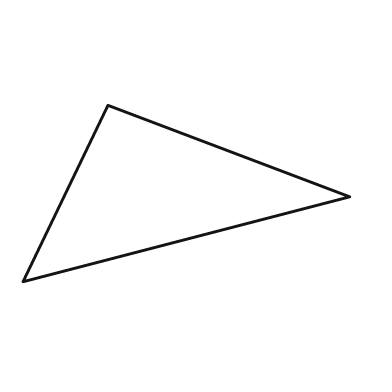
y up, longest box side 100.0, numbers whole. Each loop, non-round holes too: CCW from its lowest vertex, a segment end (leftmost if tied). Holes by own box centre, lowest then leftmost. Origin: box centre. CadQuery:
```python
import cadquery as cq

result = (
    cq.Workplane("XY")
    .moveTo(-50.0, -27.0)
    .lineTo(50.0, -1.0)
    .lineTo(-24.0, 27.0)
    .close()
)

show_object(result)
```